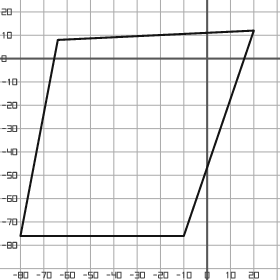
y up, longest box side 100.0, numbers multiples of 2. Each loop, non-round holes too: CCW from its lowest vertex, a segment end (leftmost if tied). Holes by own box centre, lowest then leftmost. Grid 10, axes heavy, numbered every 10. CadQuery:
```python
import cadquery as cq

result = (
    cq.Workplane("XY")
    .moveTo(-80.0, -76.0)
    .lineTo(-10.0, -76.0)
    .lineTo(20.0, 12.0)
    .lineTo(-64.0, 8.0)
    .close()
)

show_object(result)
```